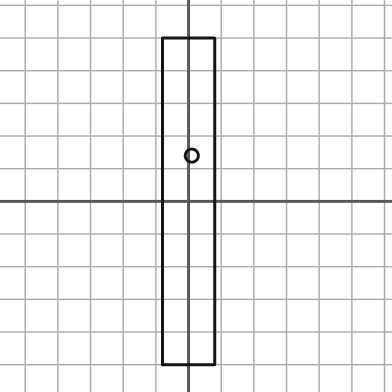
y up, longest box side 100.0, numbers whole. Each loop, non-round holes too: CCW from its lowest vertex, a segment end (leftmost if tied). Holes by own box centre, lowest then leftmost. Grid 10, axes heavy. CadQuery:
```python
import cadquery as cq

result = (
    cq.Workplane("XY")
    .moveTo(-8.0, -50.0)
    .lineTo(8.0, -50.0)
    .lineTo(8.0, 50.0)
    .lineTo(-8.0, 50.0)
    .close()
    .moveTo(1.0, 14.0)
    .circle(2.0)
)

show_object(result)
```